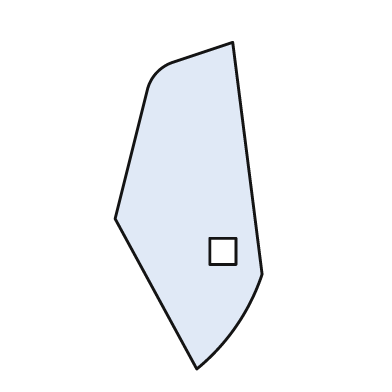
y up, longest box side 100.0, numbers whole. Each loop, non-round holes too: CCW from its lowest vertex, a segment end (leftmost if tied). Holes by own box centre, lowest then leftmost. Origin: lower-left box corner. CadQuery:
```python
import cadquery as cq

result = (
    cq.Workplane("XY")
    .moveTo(25.0, 0.0)
    .threePointArc((37.0, 13.0), (45.0, 29.0))
    .lineTo(36.0, 100.0)
    .lineTo(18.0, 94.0)
    .threePointArc((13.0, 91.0), (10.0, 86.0))
    .lineTo(0.0, 46.0)
    .close()
    .moveTo(29.0, 32.0)
    .lineTo(37.0, 32.0)
    .lineTo(37.0, 40.0)
    .lineTo(29.0, 40.0)
    .close()
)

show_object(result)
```